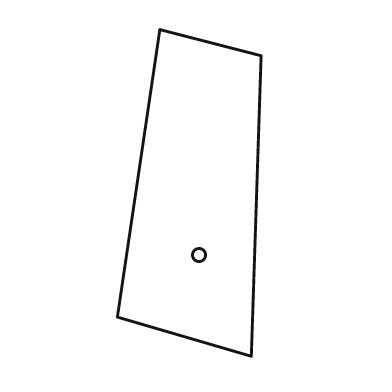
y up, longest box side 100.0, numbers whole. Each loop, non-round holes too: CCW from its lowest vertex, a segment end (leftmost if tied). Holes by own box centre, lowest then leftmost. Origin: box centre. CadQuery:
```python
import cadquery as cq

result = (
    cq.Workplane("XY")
    .moveTo(19.0, -50.0)
    .lineTo(22.0, 42.0)
    .lineTo(-9.0, 50.0)
    .lineTo(-22.0, -38.0)
    .close()
    .moveTo(3.0, -19.0)
    .circle(2.0)
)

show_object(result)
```